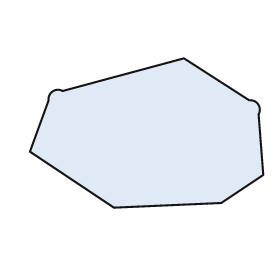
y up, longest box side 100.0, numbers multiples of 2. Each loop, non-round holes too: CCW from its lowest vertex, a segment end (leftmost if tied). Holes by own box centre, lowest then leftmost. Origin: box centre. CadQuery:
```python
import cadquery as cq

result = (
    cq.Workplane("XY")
    .moveTo(-14.0, -32.0)
    .lineTo(32.0, -30.0)
    .lineTo(50.0, -18.0)
    .lineTo(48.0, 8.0)
    .threePointArc((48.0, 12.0), (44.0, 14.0))
    .lineTo(16.0, 32.0)
    .lineTo(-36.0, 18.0)
    .threePointArc((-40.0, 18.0), (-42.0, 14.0))
    .lineTo(-50.0, -8.0)
    .close()
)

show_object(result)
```